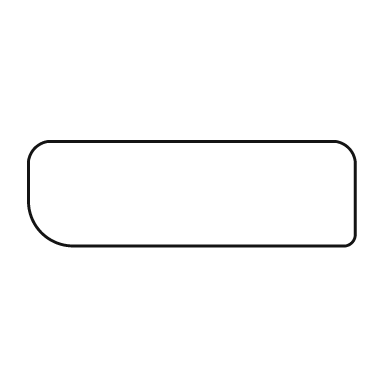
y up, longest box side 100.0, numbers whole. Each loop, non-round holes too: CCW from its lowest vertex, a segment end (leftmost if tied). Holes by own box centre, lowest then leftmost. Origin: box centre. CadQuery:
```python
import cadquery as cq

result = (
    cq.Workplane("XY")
    .moveTo(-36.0, -16.0)
    .lineTo(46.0, -16.0)
    .threePointArc((49.0, -15.0), (50.0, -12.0))
    .lineTo(50.0, 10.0)
    .threePointArc((48.0, 14.0), (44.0, 16.0))
    .lineTo(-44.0, 16.0)
    .threePointArc((-48.0, 14.0), (-50.0, 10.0))
    .lineTo(-50.0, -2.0)
    .threePointArc((-46.0, -12.0), (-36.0, -16.0))
    .close()
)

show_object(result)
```